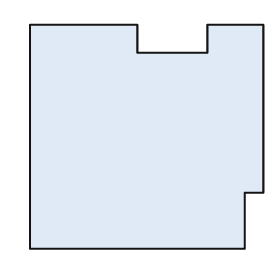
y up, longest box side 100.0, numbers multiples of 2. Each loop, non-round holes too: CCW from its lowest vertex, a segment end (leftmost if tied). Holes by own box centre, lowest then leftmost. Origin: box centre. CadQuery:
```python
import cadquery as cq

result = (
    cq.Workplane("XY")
    .moveTo(-50.0, -48.0)
    .lineTo(42.0, -48.0)
    .lineTo(42.0, -24.0)
    .lineTo(50.0, -24.0)
    .lineTo(50.0, 48.0)
    .lineTo(26.0, 48.0)
    .lineTo(26.0, 36.0)
    .lineTo(-4.0, 36.0)
    .lineTo(-4.0, 48.0)
    .lineTo(-50.0, 48.0)
    .close()
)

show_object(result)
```